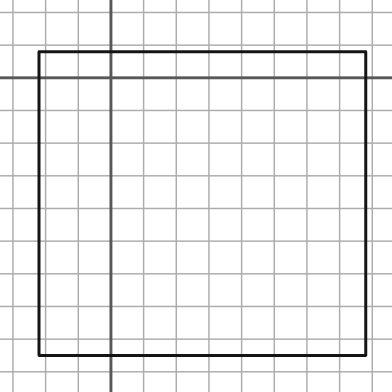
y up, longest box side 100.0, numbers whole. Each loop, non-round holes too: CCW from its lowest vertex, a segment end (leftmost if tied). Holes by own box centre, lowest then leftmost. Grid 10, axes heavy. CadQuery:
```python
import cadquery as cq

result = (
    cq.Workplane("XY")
    .moveTo(-22.0, -85.0)
    .lineTo(78.0, -85.0)
    .lineTo(78.0, 8.0)
    .lineTo(-22.0, 8.0)
    .close()
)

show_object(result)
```